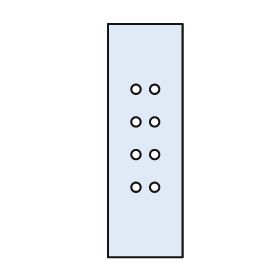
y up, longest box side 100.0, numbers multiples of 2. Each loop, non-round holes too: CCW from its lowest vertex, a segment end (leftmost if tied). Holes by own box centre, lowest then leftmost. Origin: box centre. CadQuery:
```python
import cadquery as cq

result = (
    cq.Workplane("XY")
    .moveTo(-16.0, -50.0)
    .lineTo(16.0, -50.0)
    .lineTo(16.0, 50.0)
    .lineTo(-16.0, 50.0)
    .close()
    .moveTo(-4.0, -20.0)
    .circle(2.0)
    .moveTo(4.0, -20.0)
    .circle(2.0)
    .moveTo(-4.0, -6.0)
    .circle(2.0)
    .moveTo(4.0, -6.0)
    .circle(2.0)
    .moveTo(-4.0, 8.0)
    .circle(2.0)
    .moveTo(4.0, 8.0)
    .circle(2.0)
    .moveTo(-4.0, 22.0)
    .circle(2.0)
    .moveTo(4.0, 22.0)
    .circle(2.0)
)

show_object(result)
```